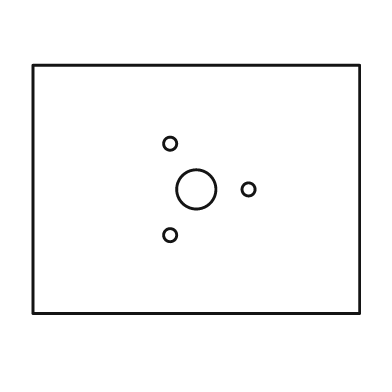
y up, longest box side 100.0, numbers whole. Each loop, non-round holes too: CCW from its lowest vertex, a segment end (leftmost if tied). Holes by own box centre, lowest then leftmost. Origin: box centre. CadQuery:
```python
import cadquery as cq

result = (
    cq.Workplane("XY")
    .moveTo(-50.0, -38.0)
    .lineTo(50.0, -38.0)
    .lineTo(50.0, 38.0)
    .lineTo(-50.0, 38.0)
    .close()
    .moveTo(-8.0, -14.0)
    .circle(2.0)
    .moveTo(0.0, 0.0)
    .circle(6.0)
    .moveTo(16.0, 0.0)
    .circle(2.0)
    .moveTo(-8.0, 14.0)
    .circle(2.0)
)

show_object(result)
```